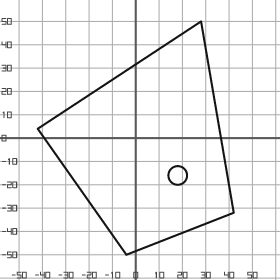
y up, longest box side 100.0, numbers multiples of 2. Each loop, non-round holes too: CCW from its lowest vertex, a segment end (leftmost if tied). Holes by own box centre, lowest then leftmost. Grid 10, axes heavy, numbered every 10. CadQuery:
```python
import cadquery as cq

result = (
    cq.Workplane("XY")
    .moveTo(-4.0, -50.0)
    .lineTo(42.0, -32.0)
    .lineTo(28.0, 50.0)
    .lineTo(-42.0, 4.0)
    .close()
    .moveTo(18.0, -16.0)
    .circle(4.0)
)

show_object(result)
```